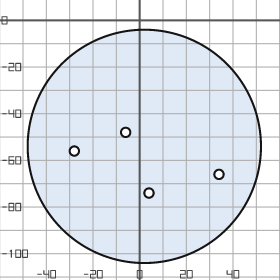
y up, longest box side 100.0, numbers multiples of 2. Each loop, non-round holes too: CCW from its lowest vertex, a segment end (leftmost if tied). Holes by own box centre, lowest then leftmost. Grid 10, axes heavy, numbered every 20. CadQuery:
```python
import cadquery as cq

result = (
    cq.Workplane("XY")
    .moveTo(2.0, -54.0)
    .circle(50.0)
    .moveTo(4.0, -74.0)
    .circle(2.0)
    .moveTo(34.0, -66.0)
    .circle(2.0)
    .moveTo(-28.0, -56.0)
    .circle(2.0)
    .moveTo(-6.0, -48.0)
    .circle(2.0)
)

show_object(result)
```